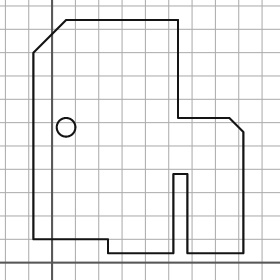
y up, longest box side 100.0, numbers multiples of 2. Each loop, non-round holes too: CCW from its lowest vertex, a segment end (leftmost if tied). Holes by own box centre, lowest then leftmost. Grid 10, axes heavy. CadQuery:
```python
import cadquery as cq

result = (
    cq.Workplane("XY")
    .moveTo(24.0, 4.0)
    .lineTo(52.0, 4.0)
    .lineTo(52.0, 38.0)
    .lineTo(58.0, 38.0)
    .lineTo(58.0, 4.0)
    .lineTo(82.0, 4.0)
    .lineTo(82.0, 56.0)
    .lineTo(76.0, 62.0)
    .lineTo(54.0, 62.0)
    .lineTo(54.0, 104.0)
    .lineTo(6.0, 104.0)
    .lineTo(-8.0, 90.0)
    .lineTo(-8.0, 10.0)
    .lineTo(24.0, 10.0)
    .close()
    .moveTo(6.0, 58.0)
    .circle(4.0)
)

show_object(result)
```